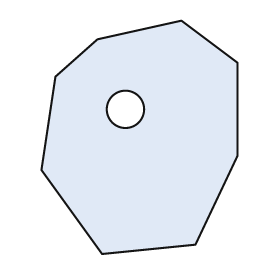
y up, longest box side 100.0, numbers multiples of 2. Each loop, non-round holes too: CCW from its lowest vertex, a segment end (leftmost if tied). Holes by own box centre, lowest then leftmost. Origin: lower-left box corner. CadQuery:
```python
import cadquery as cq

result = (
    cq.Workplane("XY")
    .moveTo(26.0, 0.0)
    .lineTo(66.0, 4.0)
    .lineTo(84.0, 42.0)
    .lineTo(84.0, 82.0)
    .lineTo(60.0, 100.0)
    .lineTo(24.0, 92.0)
    .lineTo(6.0, 76.0)
    .lineTo(0.0, 36.0)
    .close()
    .moveTo(36.0, 62.0)
    .circle(8.0)
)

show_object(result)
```